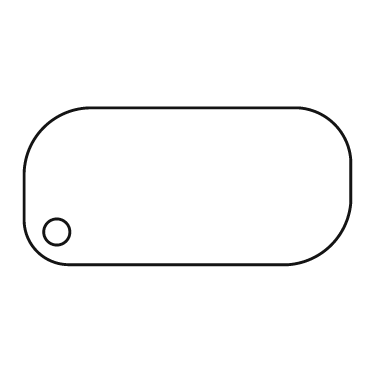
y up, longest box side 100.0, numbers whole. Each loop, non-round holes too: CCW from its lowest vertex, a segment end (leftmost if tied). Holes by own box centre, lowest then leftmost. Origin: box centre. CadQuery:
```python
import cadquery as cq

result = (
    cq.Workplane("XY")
    .moveTo(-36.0, -24.0)
    .lineTo(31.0, -24.0)
    .threePointArc((44.0, -18.0), (50.0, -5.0))
    .lineTo(50.0, 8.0)
    .threePointArc((45.0, 19.0), (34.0, 24.0))
    .lineTo(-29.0, 24.0)
    .threePointArc((-44.0, 18.0), (-50.0, 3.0))
    .lineTo(-50.0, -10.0)
    .threePointArc((-46.0, -20.0), (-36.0, -24.0))
    .close()
    .moveTo(-40.0, -14.0)
    .circle(4.0)
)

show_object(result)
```